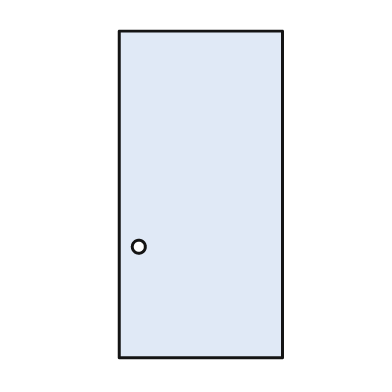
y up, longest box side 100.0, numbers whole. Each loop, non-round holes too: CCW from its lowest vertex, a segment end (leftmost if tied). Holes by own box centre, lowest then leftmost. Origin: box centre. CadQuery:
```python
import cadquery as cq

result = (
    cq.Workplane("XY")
    .moveTo(-25.0, -50.0)
    .lineTo(25.0, -50.0)
    .lineTo(25.0, 50.0)
    .lineTo(-25.0, 50.0)
    .close()
    .moveTo(-19.0, -16.0)
    .circle(2.0)
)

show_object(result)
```